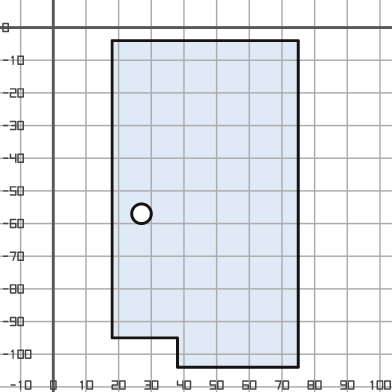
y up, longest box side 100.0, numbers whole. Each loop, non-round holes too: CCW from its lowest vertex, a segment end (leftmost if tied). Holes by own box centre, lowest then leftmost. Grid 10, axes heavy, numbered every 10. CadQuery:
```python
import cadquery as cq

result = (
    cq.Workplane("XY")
    .moveTo(38.0, -104.0)
    .lineTo(75.0, -104.0)
    .lineTo(75.0, -4.0)
    .lineTo(18.0, -4.0)
    .lineTo(18.0, -95.0)
    .lineTo(38.0, -95.0)
    .close()
    .moveTo(27.0, -57.0)
    .circle(3.0)
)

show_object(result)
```